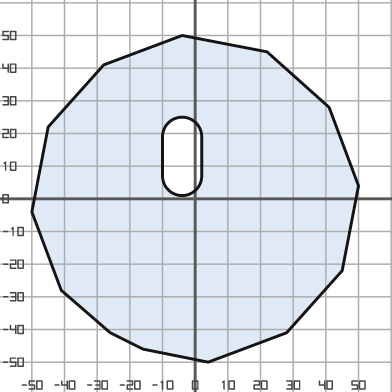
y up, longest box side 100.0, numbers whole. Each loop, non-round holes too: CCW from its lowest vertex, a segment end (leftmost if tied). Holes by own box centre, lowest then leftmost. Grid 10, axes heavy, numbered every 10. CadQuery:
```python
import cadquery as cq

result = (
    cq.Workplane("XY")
    .moveTo(4.0, -50.0)
    .lineTo(28.0, -41.0)
    .lineTo(45.0, -22.0)
    .lineTo(50.0, 4.0)
    .lineTo(41.0, 28.0)
    .lineTo(22.0, 45.0)
    .lineTo(-4.0, 50.0)
    .lineTo(-28.0, 41.0)
    .lineTo(-45.0, 22.0)
    .lineTo(-50.0, -4.0)
    .lineTo(-41.0, -28.0)
    .lineTo(-26.0, -41.0)
    .lineTo(-16.0, -46.0)
    .close()
    .moveTo(-10.0, 7.0)
    .threePointArc((-4.0, 1.0), (2.0, 7.0))
    .lineTo(2.0, 19.0)
    .threePointArc((-4.0, 25.0), (-10.0, 19.0))
    .close()
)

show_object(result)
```